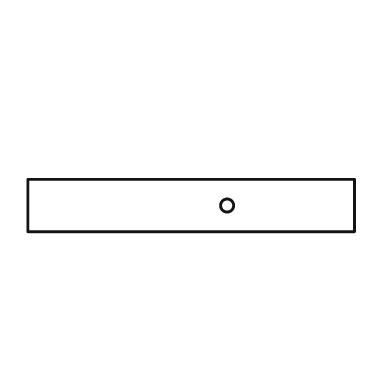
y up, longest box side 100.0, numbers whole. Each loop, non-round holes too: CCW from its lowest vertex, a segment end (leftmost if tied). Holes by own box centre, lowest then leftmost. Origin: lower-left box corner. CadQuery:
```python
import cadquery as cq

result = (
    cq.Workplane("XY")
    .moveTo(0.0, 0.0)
    .lineTo(100.0, 0.0)
    .lineTo(100.0, 16.0)
    .lineTo(0.0, 16.0)
    .close()
    .moveTo(61.0, 8.0)
    .circle(2.0)
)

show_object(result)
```